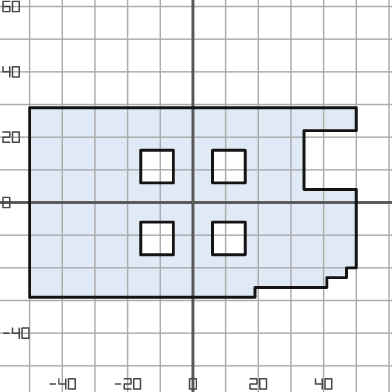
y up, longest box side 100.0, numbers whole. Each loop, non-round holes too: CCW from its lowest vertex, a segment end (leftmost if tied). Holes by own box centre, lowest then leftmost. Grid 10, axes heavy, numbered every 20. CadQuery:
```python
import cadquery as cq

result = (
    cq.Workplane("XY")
    .moveTo(-50.0, -29.0)
    .lineTo(19.0, -29.0)
    .lineTo(19.0, -26.0)
    .lineTo(41.0, -26.0)
    .lineTo(41.0, -23.0)
    .lineTo(47.0, -23.0)
    .lineTo(47.0, -20.0)
    .lineTo(50.0, -20.0)
    .lineTo(50.0, 4.0)
    .lineTo(34.0, 4.0)
    .lineTo(34.0, 22.0)
    .lineTo(50.0, 22.0)
    .lineTo(50.0, 29.0)
    .lineTo(-50.0, 29.0)
    .close()
    .moveTo(-16.0, -16.0)
    .lineTo(-6.0, -16.0)
    .lineTo(-6.0, -6.0)
    .lineTo(-16.0, -6.0)
    .close()
    .moveTo(6.0, -16.0)
    .lineTo(16.0, -16.0)
    .lineTo(16.0, -6.0)
    .lineTo(6.0, -6.0)
    .close()
    .moveTo(-16.0, 6.0)
    .lineTo(-6.0, 6.0)
    .lineTo(-6.0, 16.0)
    .lineTo(-16.0, 16.0)
    .close()
    .moveTo(6.0, 6.0)
    .lineTo(16.0, 6.0)
    .lineTo(16.0, 16.0)
    .lineTo(6.0, 16.0)
    .close()
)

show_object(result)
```